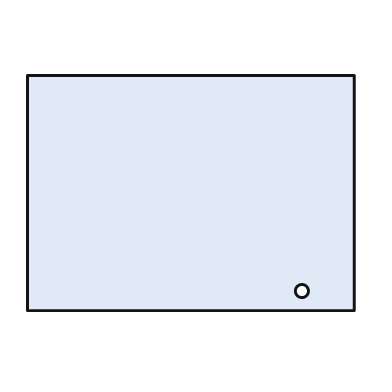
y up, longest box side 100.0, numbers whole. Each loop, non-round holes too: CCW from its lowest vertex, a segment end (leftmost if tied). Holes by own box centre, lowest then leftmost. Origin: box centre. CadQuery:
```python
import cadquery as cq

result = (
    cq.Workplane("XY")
    .moveTo(-50.0, -36.0)
    .lineTo(50.0, -36.0)
    .lineTo(50.0, 36.0)
    .lineTo(-50.0, 36.0)
    .close()
    .moveTo(34.0, -30.0)
    .circle(2.0)
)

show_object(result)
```